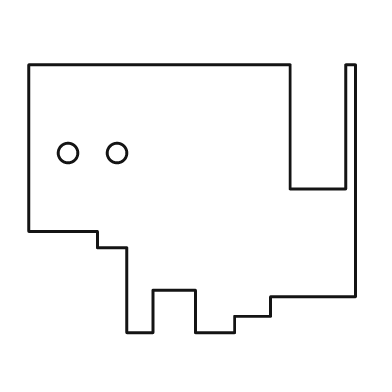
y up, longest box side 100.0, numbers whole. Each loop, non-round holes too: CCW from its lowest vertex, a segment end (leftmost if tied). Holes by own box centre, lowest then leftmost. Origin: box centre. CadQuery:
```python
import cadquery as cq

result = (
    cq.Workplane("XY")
    .moveTo(-20.0, -41.0)
    .lineTo(-12.0, -41.0)
    .lineTo(-12.0, -28.0)
    .lineTo(1.0, -28.0)
    .lineTo(1.0, -41.0)
    .lineTo(13.0, -41.0)
    .lineTo(13.0, -36.0)
    .lineTo(24.0, -36.0)
    .lineTo(24.0, -30.0)
    .lineTo(50.0, -30.0)
    .lineTo(50.0, 41.0)
    .lineTo(47.0, 41.0)
    .lineTo(47.0, 3.0)
    .lineTo(30.0, 3.0)
    .lineTo(30.0, 41.0)
    .lineTo(-50.0, 41.0)
    .lineTo(-50.0, -10.0)
    .lineTo(-29.0, -10.0)
    .lineTo(-29.0, -15.0)
    .lineTo(-20.0, -15.0)
    .close()
    .moveTo(-38.0, 14.0)
    .circle(3.0)
    .moveTo(-23.0, 14.0)
    .circle(3.0)
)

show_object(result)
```